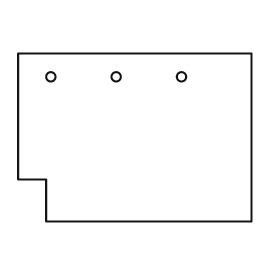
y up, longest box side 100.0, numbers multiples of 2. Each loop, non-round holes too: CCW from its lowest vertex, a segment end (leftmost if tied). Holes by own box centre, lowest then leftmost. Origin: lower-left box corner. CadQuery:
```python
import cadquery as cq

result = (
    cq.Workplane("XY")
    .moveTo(12.0, 0.0)
    .lineTo(100.0, 0.0)
    .lineTo(100.0, 72.0)
    .lineTo(0.0, 72.0)
    .lineTo(0.0, 18.0)
    .lineTo(12.0, 18.0)
    .close()
    .moveTo(14.0, 62.0)
    .circle(2.0)
    .moveTo(42.0, 62.0)
    .circle(2.0)
    .moveTo(70.0, 62.0)
    .circle(2.0)
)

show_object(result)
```